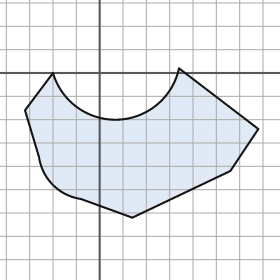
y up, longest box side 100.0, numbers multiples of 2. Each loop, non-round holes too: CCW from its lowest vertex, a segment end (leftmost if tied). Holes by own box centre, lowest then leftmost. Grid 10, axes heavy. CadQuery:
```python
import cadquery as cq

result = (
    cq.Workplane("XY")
    .moveTo(14.0, -62.0)
    .lineTo(56.0, -42.0)
    .lineTo(68.0, -24.0)
    .lineTo(34.0, 2.0)
    .threePointArc((8.0, -20.0), (-20.0, 0.0))
    .lineTo(-32.0, -16.0)
    .lineTo(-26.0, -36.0)
    .threePointArc((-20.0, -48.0), (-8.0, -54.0))
    .close()
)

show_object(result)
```